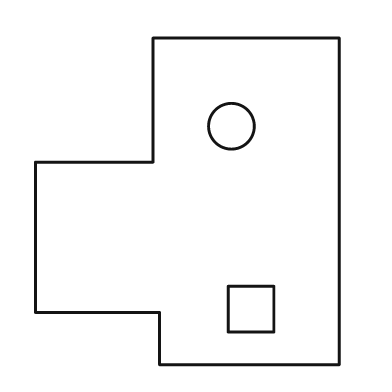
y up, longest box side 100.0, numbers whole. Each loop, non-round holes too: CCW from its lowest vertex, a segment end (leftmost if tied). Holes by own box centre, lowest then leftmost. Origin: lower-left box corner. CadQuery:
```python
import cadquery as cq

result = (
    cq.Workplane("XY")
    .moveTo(38.0, 0.0)
    .lineTo(93.0, 0.0)
    .lineTo(93.0, 100.0)
    .lineTo(36.0, 100.0)
    .lineTo(36.0, 62.0)
    .lineTo(0.0, 62.0)
    .lineTo(0.0, 16.0)
    .lineTo(38.0, 16.0)
    .close()
    .moveTo(59.0, 10.0)
    .lineTo(73.0, 10.0)
    .lineTo(73.0, 24.0)
    .lineTo(59.0, 24.0)
    .close()
    .moveTo(60.0, 73.0)
    .circle(7.0)
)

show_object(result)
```